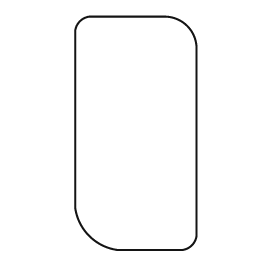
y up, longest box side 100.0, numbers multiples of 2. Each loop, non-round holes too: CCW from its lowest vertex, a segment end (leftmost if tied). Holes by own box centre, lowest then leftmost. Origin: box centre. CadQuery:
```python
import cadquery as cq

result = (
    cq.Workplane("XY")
    .moveTo(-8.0, -50.0)
    .lineTo(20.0, -50.0)
    .threePointArc((24.0, -48.0), (26.0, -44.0))
    .lineTo(26.0, 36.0)
    .threePointArc((22.0, 46.0), (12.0, 50.0))
    .lineTo(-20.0, 50.0)
    .threePointArc((-24.0, 48.0), (-26.0, 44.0))
    .lineTo(-26.0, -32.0)
    .threePointArc((-20.0, -44.0), (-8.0, -50.0))
    .close()
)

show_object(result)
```